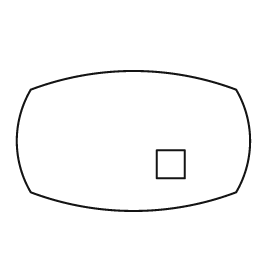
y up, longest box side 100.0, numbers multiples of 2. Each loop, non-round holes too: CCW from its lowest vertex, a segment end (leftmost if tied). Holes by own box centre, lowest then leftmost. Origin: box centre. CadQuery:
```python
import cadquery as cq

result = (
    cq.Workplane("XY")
    .moveTo(-44.0, -22.0)
    .threePointArc((0.0, -30.0), (44.0, -22.0))
    .threePointArc((50.0, 0.0), (44.0, 22.0))
    .threePointArc((0.0, 30.0), (-44.0, 22.0))
    .threePointArc((-50.0, 0.0), (-44.0, -22.0))
    .close()
    .moveTo(10.0, -16.0)
    .lineTo(22.0, -16.0)
    .lineTo(22.0, -4.0)
    .lineTo(10.0, -4.0)
    .close()
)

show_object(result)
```